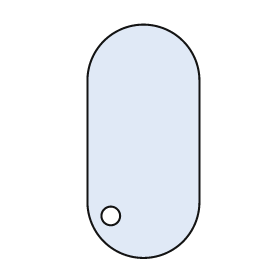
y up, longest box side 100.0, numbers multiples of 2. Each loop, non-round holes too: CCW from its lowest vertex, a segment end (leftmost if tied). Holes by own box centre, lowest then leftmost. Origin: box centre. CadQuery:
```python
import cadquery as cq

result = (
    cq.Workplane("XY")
    .moveTo(-24.0, -26.0)
    .threePointArc((0.0, -50.0), (24.0, -26.0))
    .lineTo(24.0, 26.0)
    .threePointArc((0.0, 50.0), (-24.0, 26.0))
    .close()
    .moveTo(-14.0, -32.0)
    .circle(4.0)
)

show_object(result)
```